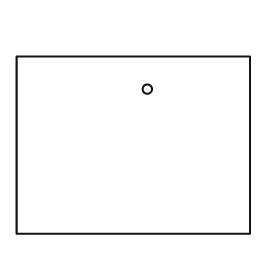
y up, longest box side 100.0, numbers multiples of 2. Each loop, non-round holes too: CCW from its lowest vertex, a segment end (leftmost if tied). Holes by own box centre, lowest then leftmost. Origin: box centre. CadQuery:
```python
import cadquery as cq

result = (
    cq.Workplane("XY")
    .moveTo(-50.0, -38.0)
    .lineTo(50.0, -38.0)
    .lineTo(50.0, 38.0)
    .lineTo(-50.0, 38.0)
    .close()
    .moveTo(6.0, 24.0)
    .circle(2.0)
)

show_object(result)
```